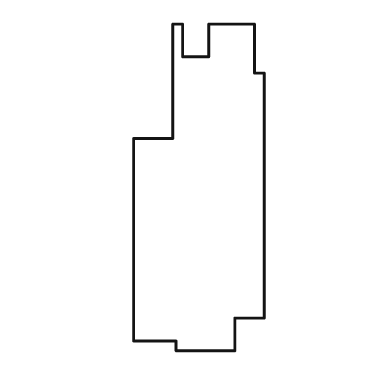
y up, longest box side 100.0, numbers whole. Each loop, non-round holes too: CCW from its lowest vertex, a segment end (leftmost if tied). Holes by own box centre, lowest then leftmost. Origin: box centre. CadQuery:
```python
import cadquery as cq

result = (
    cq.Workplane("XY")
    .moveTo(-7.0, -50.0)
    .lineTo(11.0, -50.0)
    .lineTo(11.0, -40.0)
    .lineTo(20.0, -40.0)
    .lineTo(20.0, 35.0)
    .lineTo(17.0, 35.0)
    .lineTo(17.0, 50.0)
    .lineTo(3.0, 50.0)
    .lineTo(3.0, 40.0)
    .lineTo(-5.0, 40.0)
    .lineTo(-5.0, 50.0)
    .lineTo(-8.0, 50.0)
    .lineTo(-8.0, 15.0)
    .lineTo(-20.0, 15.0)
    .lineTo(-20.0, -47.0)
    .lineTo(-7.0, -47.0)
    .close()
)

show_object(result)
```